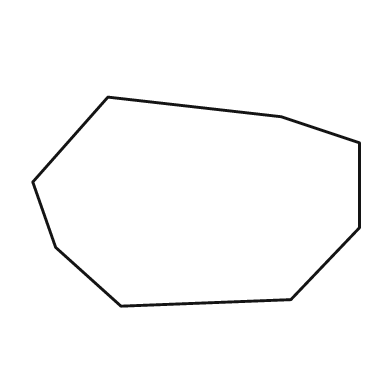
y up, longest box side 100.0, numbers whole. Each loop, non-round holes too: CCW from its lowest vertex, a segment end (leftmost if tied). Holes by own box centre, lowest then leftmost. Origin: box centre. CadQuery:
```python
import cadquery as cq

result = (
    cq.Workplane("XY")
    .moveTo(-23.0, -32.0)
    .lineTo(29.0, -30.0)
    .lineTo(50.0, -8.0)
    .lineTo(50.0, 18.0)
    .lineTo(26.0, 26.0)
    .lineTo(-27.0, 32.0)
    .lineTo(-50.0, 6.0)
    .lineTo(-43.0, -14.0)
    .close()
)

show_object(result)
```